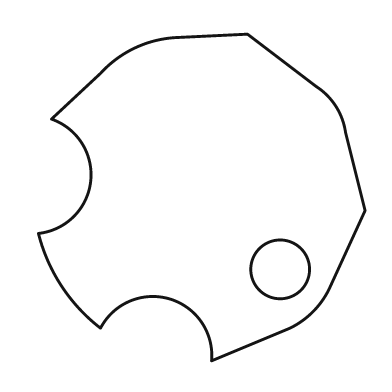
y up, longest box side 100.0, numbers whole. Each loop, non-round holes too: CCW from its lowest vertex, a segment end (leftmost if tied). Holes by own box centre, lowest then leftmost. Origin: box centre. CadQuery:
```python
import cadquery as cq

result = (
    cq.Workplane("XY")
    .moveTo(3.0, -50.0)
    .lineTo(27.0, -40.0)
    .threePointArc((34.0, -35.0), (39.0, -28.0))
    .lineTo(50.0, -4.0)
    .lineTo(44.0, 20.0)
    .threePointArc((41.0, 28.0), (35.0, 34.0))
    .lineTo(14.0, 50.0)
    .lineTo(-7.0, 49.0)
    .threePointArc((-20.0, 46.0), (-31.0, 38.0))
    .lineTo(-46.0, 24.0)
    .threePointArc((-34.0, 5.0), (-50.0, -11.0))
    .threePointArc((-43.0, -27.0), (-31.0, -40.0))
    .threePointArc((-10.0, -31.0), (3.0, -50.0))
    .close()
    .moveTo(24.0, -22.0)
    .circle(9.0)
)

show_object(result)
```